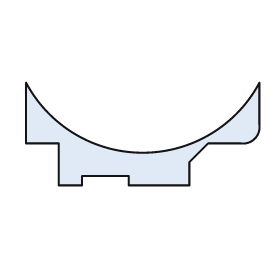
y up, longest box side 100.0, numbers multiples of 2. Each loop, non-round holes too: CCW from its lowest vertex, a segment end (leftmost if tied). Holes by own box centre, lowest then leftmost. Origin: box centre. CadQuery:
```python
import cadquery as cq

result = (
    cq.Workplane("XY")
    .moveTo(-36.0, -22.0)
    .lineTo(-26.0, -22.0)
    .lineTo(-26.0, -18.0)
    .lineTo(-6.0, -18.0)
    .lineTo(-6.0, -22.0)
    .lineTo(20.0, -22.0)
    .lineTo(20.0, -12.0)
    .lineTo(28.0, -4.0)
    .lineTo(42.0, -4.0)
    .threePointArc((48.0, -2.0), (50.0, 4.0))
    .lineTo(50.0, 22.0)
    .threePointArc((0.0, -8.0), (-50.0, 22.0))
    .lineTo(-50.0, -4.0)
    .lineTo(-36.0, -4.0)
    .close()
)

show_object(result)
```